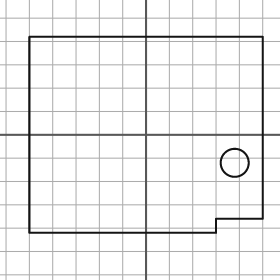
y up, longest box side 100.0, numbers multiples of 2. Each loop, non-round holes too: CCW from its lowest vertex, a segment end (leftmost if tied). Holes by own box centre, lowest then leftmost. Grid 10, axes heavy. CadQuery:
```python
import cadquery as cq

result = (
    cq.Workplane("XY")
    .moveTo(-50.0, -42.0)
    .lineTo(30.0, -42.0)
    .lineTo(30.0, -36.0)
    .lineTo(50.0, -36.0)
    .lineTo(50.0, 42.0)
    .lineTo(-50.0, 42.0)
    .close()
    .moveTo(38.0, -12.0)
    .circle(6.0)
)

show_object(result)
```